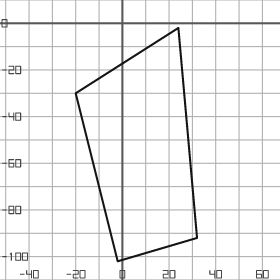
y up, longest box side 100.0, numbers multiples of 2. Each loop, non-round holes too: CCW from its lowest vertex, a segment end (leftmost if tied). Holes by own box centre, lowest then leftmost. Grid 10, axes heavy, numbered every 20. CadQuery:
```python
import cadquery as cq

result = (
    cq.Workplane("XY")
    .moveTo(-2.0, -102.0)
    .lineTo(32.0, -92.0)
    .lineTo(24.0, -2.0)
    .lineTo(-20.0, -30.0)
    .close()
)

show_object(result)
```